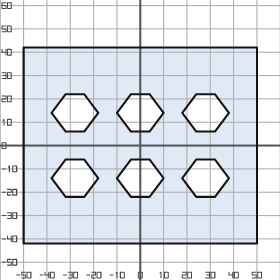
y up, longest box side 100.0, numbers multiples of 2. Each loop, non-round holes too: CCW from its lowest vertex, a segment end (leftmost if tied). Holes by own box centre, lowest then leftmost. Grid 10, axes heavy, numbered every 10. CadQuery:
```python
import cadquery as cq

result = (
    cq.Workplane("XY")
    .moveTo(-50.0, -42.0)
    .lineTo(50.0, -42.0)
    .lineTo(50.0, 42.0)
    .lineTo(-50.0, 42.0)
    .close()
    .moveTo(-32.0, -22.0)
    .lineTo(-24.0, -22.0)
    .lineTo(-18.0, -14.0)
    .lineTo(-24.0, -6.0)
    .lineTo(-32.0, -6.0)
    .lineTo(-38.0, -14.0)
    .close()
    .moveTo(-4.0, -22.0)
    .lineTo(4.0, -22.0)
    .lineTo(10.0, -14.0)
    .lineTo(4.0, -6.0)
    .lineTo(-4.0, -6.0)
    .lineTo(-10.0, -14.0)
    .close()
    .moveTo(24.0, -22.0)
    .lineTo(32.0, -22.0)
    .lineTo(38.0, -14.0)
    .lineTo(32.0, -6.0)
    .lineTo(24.0, -6.0)
    .lineTo(18.0, -14.0)
    .close()
    .moveTo(-32.0, 6.0)
    .lineTo(-24.0, 6.0)
    .lineTo(-18.0, 14.0)
    .lineTo(-24.0, 22.0)
    .lineTo(-32.0, 22.0)
    .lineTo(-38.0, 14.0)
    .close()
    .moveTo(-4.0, 6.0)
    .lineTo(4.0, 6.0)
    .lineTo(10.0, 14.0)
    .lineTo(4.0, 22.0)
    .lineTo(-4.0, 22.0)
    .lineTo(-10.0, 14.0)
    .close()
    .moveTo(24.0, 6.0)
    .lineTo(32.0, 6.0)
    .lineTo(38.0, 14.0)
    .lineTo(32.0, 22.0)
    .lineTo(24.0, 22.0)
    .lineTo(18.0, 14.0)
    .close()
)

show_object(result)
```